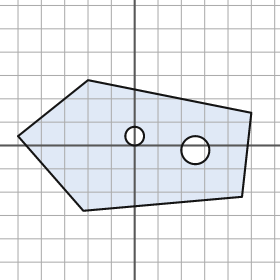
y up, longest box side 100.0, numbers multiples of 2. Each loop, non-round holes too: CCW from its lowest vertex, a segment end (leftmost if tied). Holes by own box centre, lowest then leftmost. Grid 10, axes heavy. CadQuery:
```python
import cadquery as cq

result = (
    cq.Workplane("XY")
    .moveTo(-22.0, -28.0)
    .lineTo(46.0, -22.0)
    .lineTo(50.0, 14.0)
    .lineTo(-20.0, 28.0)
    .lineTo(-50.0, 4.0)
    .close()
    .moveTo(26.0, -2.0)
    .circle(6.0)
    .moveTo(0.0, 4.0)
    .circle(4.0)
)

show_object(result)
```